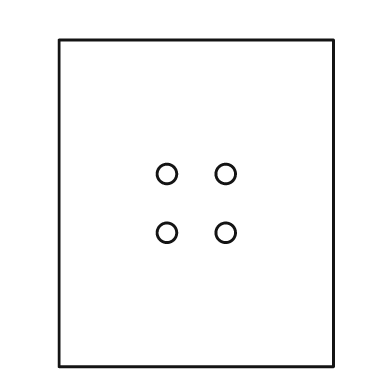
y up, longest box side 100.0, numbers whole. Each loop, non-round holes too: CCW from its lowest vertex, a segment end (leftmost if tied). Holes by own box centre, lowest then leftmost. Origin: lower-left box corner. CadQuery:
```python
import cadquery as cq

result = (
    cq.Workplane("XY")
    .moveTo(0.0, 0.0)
    .lineTo(84.0, 0.0)
    .lineTo(84.0, 100.0)
    .lineTo(0.0, 100.0)
    .close()
    .moveTo(33.0, 41.0)
    .circle(3.0)
    .moveTo(51.0, 41.0)
    .circle(3.0)
    .moveTo(33.0, 59.0)
    .circle(3.0)
    .moveTo(51.0, 59.0)
    .circle(3.0)
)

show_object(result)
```